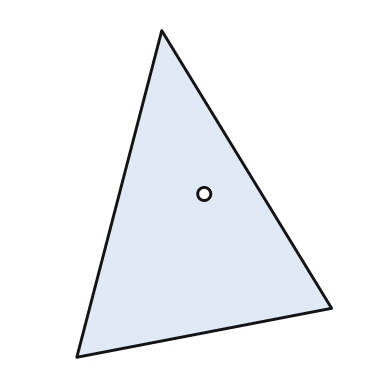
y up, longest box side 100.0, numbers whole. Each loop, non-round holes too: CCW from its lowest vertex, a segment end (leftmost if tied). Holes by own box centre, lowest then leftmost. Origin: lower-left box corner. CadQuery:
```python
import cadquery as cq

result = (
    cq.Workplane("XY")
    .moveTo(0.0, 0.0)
    .lineTo(78.0, 15.0)
    .lineTo(26.0, 100.0)
    .close()
    .moveTo(39.0, 50.0)
    .circle(2.0)
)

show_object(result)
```